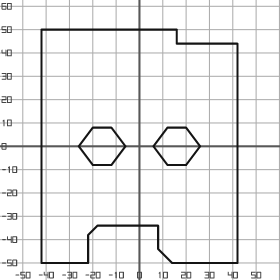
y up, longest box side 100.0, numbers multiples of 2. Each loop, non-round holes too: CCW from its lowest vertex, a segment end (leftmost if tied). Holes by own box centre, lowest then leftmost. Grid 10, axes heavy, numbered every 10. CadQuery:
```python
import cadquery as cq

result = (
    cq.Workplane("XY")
    .moveTo(-42.0, -50.0)
    .lineTo(-22.0, -50.0)
    .lineTo(-22.0, -38.0)
    .lineTo(-18.0, -34.0)
    .lineTo(8.0, -34.0)
    .lineTo(8.0, -44.0)
    .lineTo(14.0, -50.0)
    .lineTo(42.0, -50.0)
    .lineTo(42.0, 44.0)
    .lineTo(16.0, 44.0)
    .lineTo(16.0, 50.0)
    .lineTo(-42.0, 50.0)
    .close()
    .moveTo(-20.0, -8.0)
    .lineTo(-12.0, -8.0)
    .lineTo(-6.0, 0.0)
    .lineTo(-12.0, 8.0)
    .lineTo(-20.0, 8.0)
    .lineTo(-26.0, 0.0)
    .close()
    .moveTo(12.0, -8.0)
    .lineTo(20.0, -8.0)
    .lineTo(26.0, 0.0)
    .lineTo(20.0, 8.0)
    .lineTo(12.0, 8.0)
    .lineTo(6.0, 0.0)
    .close()
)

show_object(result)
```